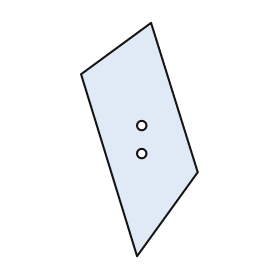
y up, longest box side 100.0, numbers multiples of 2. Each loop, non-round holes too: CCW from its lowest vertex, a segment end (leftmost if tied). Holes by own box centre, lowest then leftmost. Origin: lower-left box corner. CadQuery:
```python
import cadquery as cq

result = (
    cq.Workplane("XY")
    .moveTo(24.0, 0.0)
    .lineTo(50.0, 36.0)
    .lineTo(30.0, 100.0)
    .lineTo(0.0, 78.0)
    .close()
    .moveTo(26.0, 44.0)
    .circle(2.0)
    .moveTo(26.0, 56.0)
    .circle(2.0)
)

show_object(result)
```